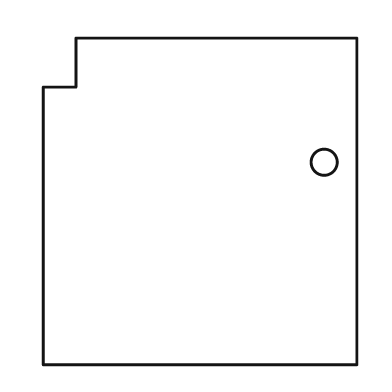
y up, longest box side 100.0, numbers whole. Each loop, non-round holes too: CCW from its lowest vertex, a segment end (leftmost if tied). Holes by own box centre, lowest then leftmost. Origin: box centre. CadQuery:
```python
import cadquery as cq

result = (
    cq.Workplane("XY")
    .moveTo(-48.0, -50.0)
    .lineTo(48.0, -50.0)
    .lineTo(48.0, 50.0)
    .lineTo(-38.0, 50.0)
    .lineTo(-38.0, 35.0)
    .lineTo(-48.0, 35.0)
    .close()
    .moveTo(38.0, 12.0)
    .circle(4.0)
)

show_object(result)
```